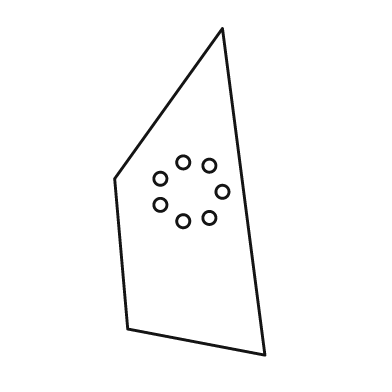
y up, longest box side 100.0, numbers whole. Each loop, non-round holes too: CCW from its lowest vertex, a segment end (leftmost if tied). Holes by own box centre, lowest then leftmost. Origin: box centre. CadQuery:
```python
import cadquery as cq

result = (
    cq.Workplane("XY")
    .moveTo(23.0, -50.0)
    .lineTo(10.0, 50.0)
    .lineTo(-23.0, 4.0)
    .lineTo(-19.0, -42.0)
    .close()
    .moveTo(-2.0, -9.0)
    .circle(2.0)
    .moveTo(6.0, -8.0)
    .circle(2.0)
    .moveTo(-9.0, -4.0)
    .circle(2.0)
    .moveTo(10.0, 0.0)
    .circle(2.0)
    .moveTo(-9.0, 4.0)
    .circle(2.0)
    .moveTo(6.0, 8.0)
    .circle(2.0)
    .moveTo(-2.0, 9.0)
    .circle(2.0)
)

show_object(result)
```